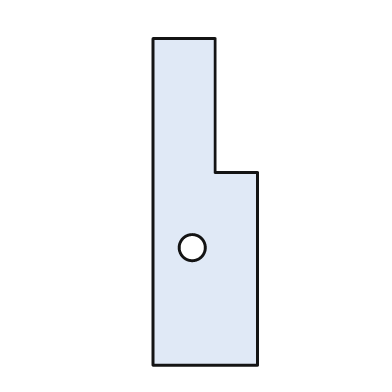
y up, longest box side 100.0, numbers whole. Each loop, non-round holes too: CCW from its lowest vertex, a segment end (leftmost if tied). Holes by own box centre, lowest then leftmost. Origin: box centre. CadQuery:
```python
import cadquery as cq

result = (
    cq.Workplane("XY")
    .moveTo(-16.0, -50.0)
    .lineTo(16.0, -50.0)
    .lineTo(16.0, 9.0)
    .lineTo(3.0, 9.0)
    .lineTo(3.0, 50.0)
    .lineTo(-16.0, 50.0)
    .close()
    .moveTo(-4.0, -14.0)
    .circle(4.0)
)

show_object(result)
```